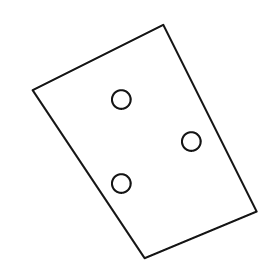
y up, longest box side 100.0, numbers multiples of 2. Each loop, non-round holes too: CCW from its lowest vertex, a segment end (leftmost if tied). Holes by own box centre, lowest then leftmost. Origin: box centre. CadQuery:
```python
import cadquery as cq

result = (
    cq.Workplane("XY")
    .moveTo(0.0, -50.0)
    .lineTo(48.0, -30.0)
    .lineTo(8.0, 50.0)
    .lineTo(-48.0, 22.0)
    .close()
    .moveTo(-10.0, -18.0)
    .circle(4.0)
    .moveTo(20.0, 0.0)
    .circle(4.0)
    .moveTo(-10.0, 18.0)
    .circle(4.0)
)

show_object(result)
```